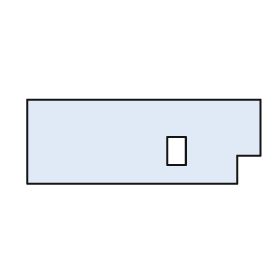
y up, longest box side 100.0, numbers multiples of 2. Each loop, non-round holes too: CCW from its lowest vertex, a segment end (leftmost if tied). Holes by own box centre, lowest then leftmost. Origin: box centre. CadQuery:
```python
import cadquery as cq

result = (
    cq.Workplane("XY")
    .moveTo(-50.0, -18.0)
    .lineTo(40.0, -18.0)
    .lineTo(40.0, -6.0)
    .lineTo(50.0, -6.0)
    .lineTo(50.0, 18.0)
    .lineTo(-50.0, 18.0)
    .close()
    .moveTo(10.0, -10.0)
    .lineTo(18.0, -10.0)
    .lineTo(18.0, 2.0)
    .lineTo(10.0, 2.0)
    .close()
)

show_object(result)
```